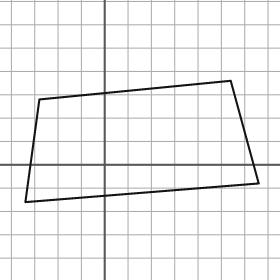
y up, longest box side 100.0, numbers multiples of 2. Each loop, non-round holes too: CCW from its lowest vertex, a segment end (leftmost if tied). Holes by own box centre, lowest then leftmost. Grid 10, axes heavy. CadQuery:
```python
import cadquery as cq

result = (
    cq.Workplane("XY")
    .moveTo(-34.0, -16.0)
    .lineTo(66.0, -8.0)
    .lineTo(54.0, 36.0)
    .lineTo(-28.0, 28.0)
    .close()
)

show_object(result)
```